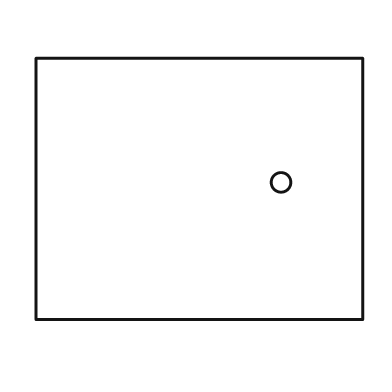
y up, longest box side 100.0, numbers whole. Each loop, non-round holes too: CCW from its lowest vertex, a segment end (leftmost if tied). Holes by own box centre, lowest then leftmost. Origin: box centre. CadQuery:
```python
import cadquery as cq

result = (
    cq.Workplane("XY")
    .moveTo(-50.0, -40.0)
    .lineTo(50.0, -40.0)
    .lineTo(50.0, 40.0)
    .lineTo(-50.0, 40.0)
    .close()
    .moveTo(25.0, 2.0)
    .circle(3.0)
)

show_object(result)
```